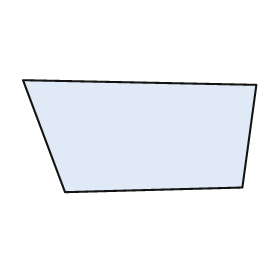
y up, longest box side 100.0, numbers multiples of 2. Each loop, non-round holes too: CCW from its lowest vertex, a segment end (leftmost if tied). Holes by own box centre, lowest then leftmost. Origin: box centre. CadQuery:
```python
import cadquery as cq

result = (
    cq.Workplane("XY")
    .moveTo(-32.0, -24.0)
    .lineTo(44.0, -22.0)
    .lineTo(50.0, 22.0)
    .lineTo(-50.0, 24.0)
    .close()
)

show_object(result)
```